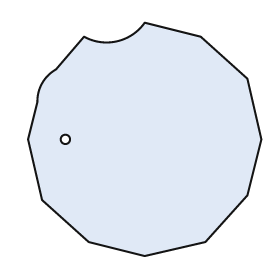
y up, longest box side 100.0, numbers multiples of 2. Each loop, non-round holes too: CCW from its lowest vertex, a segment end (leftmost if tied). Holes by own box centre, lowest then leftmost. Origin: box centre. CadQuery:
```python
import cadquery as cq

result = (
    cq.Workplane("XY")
    .moveTo(0.0, -50.0)
    .lineTo(26.0, -44.0)
    .lineTo(44.0, -24.0)
    .lineTo(50.0, 0.0)
    .lineTo(44.0, 26.0)
    .lineTo(24.0, 44.0)
    .lineTo(0.0, 50.0)
    .threePointArc((-12.0, 42.0), (-26.0, 44.0))
    .lineTo(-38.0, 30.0)
    .threePointArc((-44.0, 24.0), (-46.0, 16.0))
    .lineTo(-50.0, 0.0)
    .lineTo(-44.0, -26.0)
    .lineTo(-24.0, -44.0)
    .close()
    .moveTo(-34.0, 0.0)
    .circle(2.0)
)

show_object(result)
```